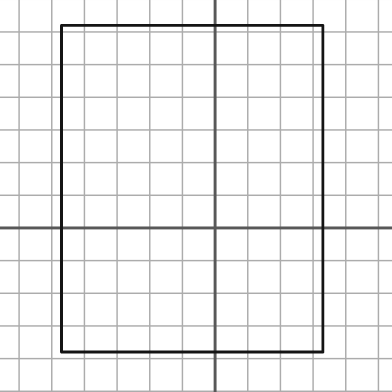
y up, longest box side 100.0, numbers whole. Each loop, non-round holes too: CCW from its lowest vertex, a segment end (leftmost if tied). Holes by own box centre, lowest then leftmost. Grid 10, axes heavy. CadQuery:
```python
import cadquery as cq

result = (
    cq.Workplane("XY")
    .moveTo(-47.0, -38.0)
    .lineTo(33.0, -38.0)
    .lineTo(33.0, 62.0)
    .lineTo(-47.0, 62.0)
    .close()
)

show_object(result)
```